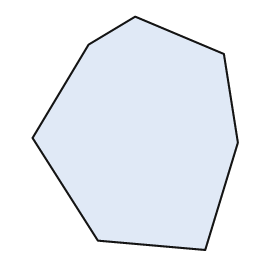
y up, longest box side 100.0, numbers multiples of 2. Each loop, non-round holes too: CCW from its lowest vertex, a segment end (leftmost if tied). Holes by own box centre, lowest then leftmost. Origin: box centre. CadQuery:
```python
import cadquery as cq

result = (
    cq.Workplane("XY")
    .moveTo(30.0, -50.0)
    .lineTo(44.0, -4.0)
    .lineTo(38.0, 34.0)
    .lineTo(0.0, 50.0)
    .lineTo(-20.0, 38.0)
    .lineTo(-44.0, -2.0)
    .lineTo(-16.0, -46.0)
    .close()
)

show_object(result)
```